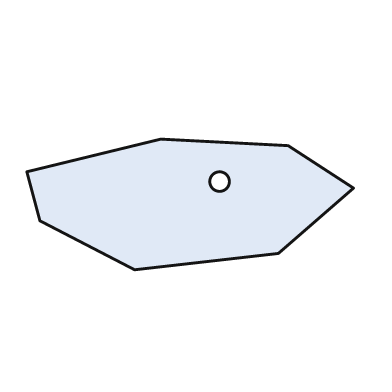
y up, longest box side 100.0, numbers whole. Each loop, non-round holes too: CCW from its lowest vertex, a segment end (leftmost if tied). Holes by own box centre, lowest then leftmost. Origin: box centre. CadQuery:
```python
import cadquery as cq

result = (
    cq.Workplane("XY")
    .moveTo(-17.0, -20.0)
    .lineTo(27.0, -15.0)
    .lineTo(50.0, 5.0)
    .lineTo(30.0, 18.0)
    .lineTo(-9.0, 20.0)
    .lineTo(-50.0, 10.0)
    .lineTo(-46.0, -5.0)
    .close()
    .moveTo(9.0, 7.0)
    .circle(3.0)
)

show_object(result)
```